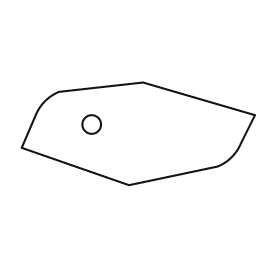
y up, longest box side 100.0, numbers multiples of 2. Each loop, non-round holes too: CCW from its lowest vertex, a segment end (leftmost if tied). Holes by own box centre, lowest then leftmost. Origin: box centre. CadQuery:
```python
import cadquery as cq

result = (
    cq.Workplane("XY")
    .moveTo(-4.0, -22.0)
    .lineTo(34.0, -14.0)
    .threePointArc((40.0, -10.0), (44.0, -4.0))
    .lineTo(50.0, 8.0)
    .lineTo(2.0, 22.0)
    .lineTo(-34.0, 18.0)
    .threePointArc((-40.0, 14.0), (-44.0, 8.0))
    .lineTo(-50.0, -6.0)
    .close()
    .moveTo(-20.0, 4.0)
    .circle(4.0)
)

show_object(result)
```